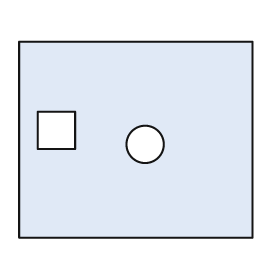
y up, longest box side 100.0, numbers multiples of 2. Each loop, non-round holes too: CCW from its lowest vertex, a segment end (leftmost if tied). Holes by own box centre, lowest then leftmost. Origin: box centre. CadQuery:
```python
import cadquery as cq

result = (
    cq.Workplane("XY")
    .moveTo(-50.0, -42.0)
    .lineTo(50.0, -42.0)
    .lineTo(50.0, 42.0)
    .lineTo(-50.0, 42.0)
    .close()
    .moveTo(4.0, -2.0)
    .circle(8.0)
    .moveTo(-42.0, -4.0)
    .lineTo(-26.0, -4.0)
    .lineTo(-26.0, 12.0)
    .lineTo(-42.0, 12.0)
    .close()
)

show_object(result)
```